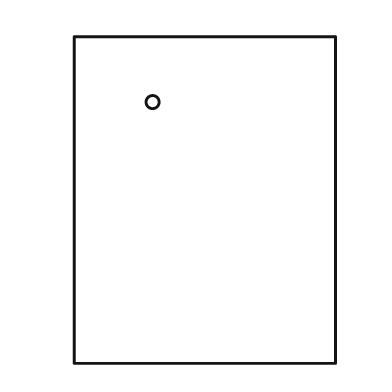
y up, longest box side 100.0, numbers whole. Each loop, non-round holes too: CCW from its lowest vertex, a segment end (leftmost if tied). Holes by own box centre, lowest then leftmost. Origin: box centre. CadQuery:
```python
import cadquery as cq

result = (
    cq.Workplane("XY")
    .moveTo(-40.0, -50.0)
    .lineTo(40.0, -50.0)
    .lineTo(40.0, 50.0)
    .lineTo(-40.0, 50.0)
    .close()
    .moveTo(-16.0, 30.0)
    .circle(2.0)
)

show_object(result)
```